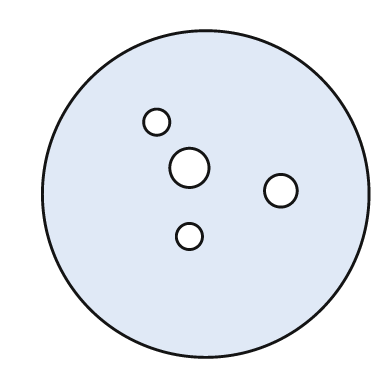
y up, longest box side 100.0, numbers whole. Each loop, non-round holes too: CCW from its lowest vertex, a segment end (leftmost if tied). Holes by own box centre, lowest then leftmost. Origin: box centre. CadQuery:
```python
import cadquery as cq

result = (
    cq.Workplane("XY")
    .moveTo(0.0, 0.0)
    .circle(50.0)
    .moveTo(-5.0, -13.0)
    .circle(4.0)
    .moveTo(23.0, 1.0)
    .circle(5.0)
    .moveTo(-5.0, 8.0)
    .circle(6.0)
    .moveTo(-15.0, 22.0)
    .circle(4.0)
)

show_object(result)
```